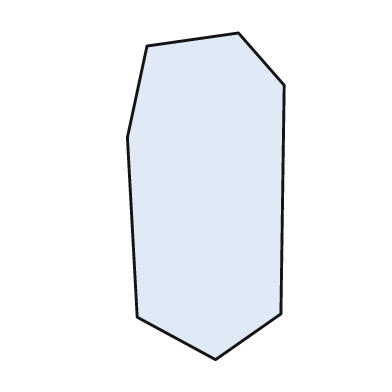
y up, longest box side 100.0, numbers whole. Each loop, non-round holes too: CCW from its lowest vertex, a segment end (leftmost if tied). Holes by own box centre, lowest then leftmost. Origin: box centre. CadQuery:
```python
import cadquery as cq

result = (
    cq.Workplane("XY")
    .moveTo(3.0, -50.0)
    .lineTo(23.0, -36.0)
    .lineTo(24.0, 34.0)
    .lineTo(10.0, 50.0)
    .lineTo(-18.0, 46.0)
    .lineTo(-24.0, 18.0)
    .lineTo(-21.0, -37.0)
    .close()
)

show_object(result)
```